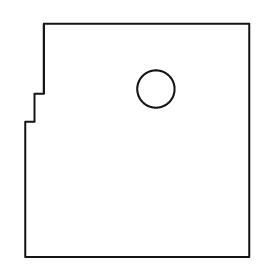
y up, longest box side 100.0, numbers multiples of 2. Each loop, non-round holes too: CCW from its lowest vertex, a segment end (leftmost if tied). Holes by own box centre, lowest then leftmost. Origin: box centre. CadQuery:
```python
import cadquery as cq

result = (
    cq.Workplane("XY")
    .moveTo(-48.0, -50.0)
    .lineTo(48.0, -50.0)
    .lineTo(48.0, 50.0)
    .lineTo(-40.0, 50.0)
    .lineTo(-40.0, 20.0)
    .lineTo(-44.0, 20.0)
    .lineTo(-44.0, 8.0)
    .lineTo(-48.0, 8.0)
    .close()
    .moveTo(8.0, 22.0)
    .circle(8.0)
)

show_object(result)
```